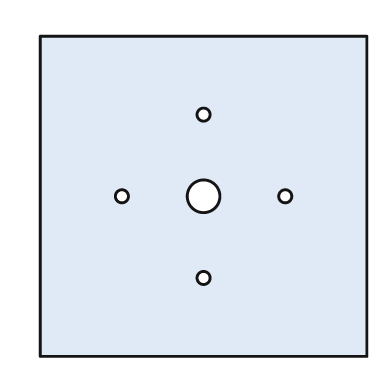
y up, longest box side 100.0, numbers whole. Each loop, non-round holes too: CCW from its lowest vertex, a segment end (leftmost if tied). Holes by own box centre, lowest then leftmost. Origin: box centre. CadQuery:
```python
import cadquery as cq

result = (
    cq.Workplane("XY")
    .moveTo(-50.0, -49.0)
    .lineTo(50.0, -49.0)
    .lineTo(50.0, 49.0)
    .lineTo(-50.0, 49.0)
    .close()
    .moveTo(0.0, -25.0)
    .circle(2.0)
    .moveTo(-25.0, 0.0)
    .circle(2.0)
    .moveTo(0.0, 0.0)
    .circle(5.0)
    .moveTo(25.0, 0.0)
    .circle(2.0)
    .moveTo(0.0, 25.0)
    .circle(2.0)
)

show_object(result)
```